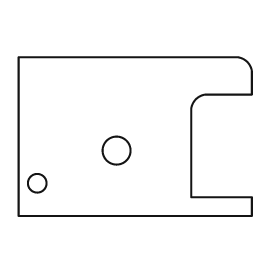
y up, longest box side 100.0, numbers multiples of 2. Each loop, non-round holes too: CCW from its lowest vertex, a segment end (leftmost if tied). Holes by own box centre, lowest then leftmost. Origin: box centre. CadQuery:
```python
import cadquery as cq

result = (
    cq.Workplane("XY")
    .moveTo(-50.0, -34.0)
    .lineTo(50.0, -34.0)
    .lineTo(50.0, -26.0)
    .lineTo(24.0, -26.0)
    .lineTo(24.0, 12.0)
    .threePointArc((26.0, 16.0), (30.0, 18.0))
    .lineTo(50.0, 18.0)
    .lineTo(50.0, 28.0)
    .threePointArc((48.0, 32.0), (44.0, 34.0))
    .lineTo(-50.0, 34.0)
    .close()
    .moveTo(-42.0, -20.0)
    .circle(4.0)
    .moveTo(-8.0, -6.0)
    .circle(6.0)
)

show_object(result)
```